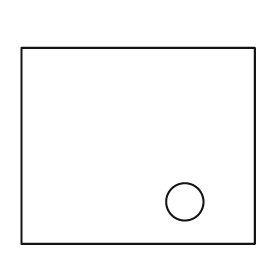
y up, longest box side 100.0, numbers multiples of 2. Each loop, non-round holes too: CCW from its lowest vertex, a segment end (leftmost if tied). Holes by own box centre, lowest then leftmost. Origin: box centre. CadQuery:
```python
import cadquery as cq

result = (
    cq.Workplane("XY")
    .moveTo(-50.0, -42.0)
    .lineTo(50.0, -42.0)
    .lineTo(50.0, 42.0)
    .lineTo(-50.0, 42.0)
    .close()
    .moveTo(20.0, -24.0)
    .circle(8.0)
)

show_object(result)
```